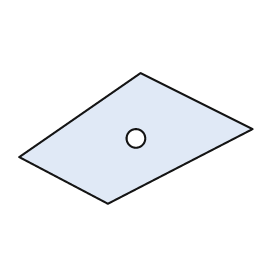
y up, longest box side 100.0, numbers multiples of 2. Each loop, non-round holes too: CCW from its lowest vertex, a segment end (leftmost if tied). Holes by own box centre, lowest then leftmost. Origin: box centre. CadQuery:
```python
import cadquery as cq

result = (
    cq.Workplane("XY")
    .moveTo(-12.0, -28.0)
    .lineTo(50.0, 4.0)
    .lineTo(2.0, 28.0)
    .lineTo(-50.0, -8.0)
    .close()
    .moveTo(0.0, 0.0)
    .circle(4.0)
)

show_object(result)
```